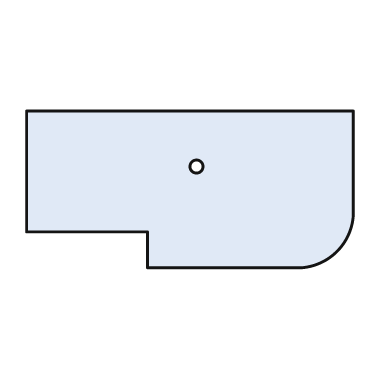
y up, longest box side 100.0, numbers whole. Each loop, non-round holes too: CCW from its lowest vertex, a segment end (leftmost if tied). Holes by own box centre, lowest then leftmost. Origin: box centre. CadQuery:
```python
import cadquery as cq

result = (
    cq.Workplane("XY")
    .moveTo(-13.0, -24.0)
    .lineTo(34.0, -24.0)
    .threePointArc((45.0, -19.0), (50.0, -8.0))
    .lineTo(50.0, 24.0)
    .lineTo(-50.0, 24.0)
    .lineTo(-50.0, -13.0)
    .lineTo(-13.0, -13.0)
    .close()
    .moveTo(2.0, 7.0)
    .circle(2.0)
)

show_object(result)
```